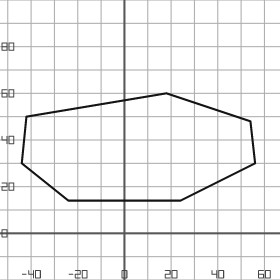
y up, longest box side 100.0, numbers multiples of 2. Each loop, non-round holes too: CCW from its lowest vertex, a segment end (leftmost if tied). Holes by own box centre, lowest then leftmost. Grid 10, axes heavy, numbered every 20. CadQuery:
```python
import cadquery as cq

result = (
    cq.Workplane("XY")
    .moveTo(-24.0, 14.0)
    .lineTo(24.0, 14.0)
    .lineTo(56.0, 30.0)
    .lineTo(54.0, 48.0)
    .lineTo(18.0, 60.0)
    .lineTo(-42.0, 50.0)
    .lineTo(-44.0, 30.0)
    .close()
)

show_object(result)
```